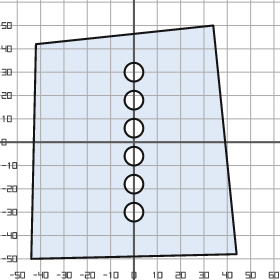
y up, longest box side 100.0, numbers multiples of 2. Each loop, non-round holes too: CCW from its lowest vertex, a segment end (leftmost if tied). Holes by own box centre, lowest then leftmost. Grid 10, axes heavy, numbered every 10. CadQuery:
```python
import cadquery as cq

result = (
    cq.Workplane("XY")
    .moveTo(-44.0, -50.0)
    .lineTo(44.0, -48.0)
    .lineTo(34.0, 50.0)
    .lineTo(-42.0, 42.0)
    .close()
    .moveTo(0.0, -30.0)
    .circle(4.0)
    .moveTo(0.0, -18.0)
    .circle(4.0)
    .moveTo(0.0, -6.0)
    .circle(4.0)
    .moveTo(0.0, 6.0)
    .circle(4.0)
    .moveTo(0.0, 18.0)
    .circle(4.0)
    .moveTo(0.0, 30.0)
    .circle(4.0)
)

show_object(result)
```